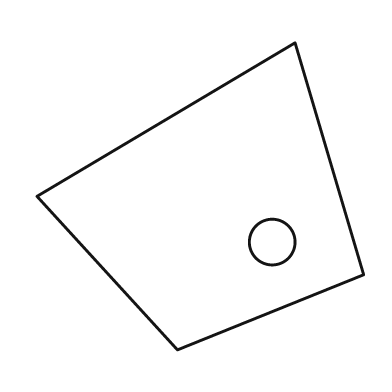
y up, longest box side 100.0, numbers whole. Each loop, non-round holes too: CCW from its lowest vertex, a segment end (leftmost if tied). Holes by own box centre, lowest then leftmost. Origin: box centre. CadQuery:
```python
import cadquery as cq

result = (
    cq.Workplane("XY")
    .moveTo(-7.0, -47.0)
    .lineTo(50.0, -24.0)
    .lineTo(29.0, 47.0)
    .lineTo(-50.0, 0.0)
    .close()
    .moveTo(22.0, -14.0)
    .circle(7.0)
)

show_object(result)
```